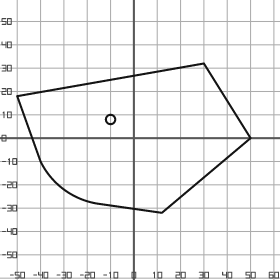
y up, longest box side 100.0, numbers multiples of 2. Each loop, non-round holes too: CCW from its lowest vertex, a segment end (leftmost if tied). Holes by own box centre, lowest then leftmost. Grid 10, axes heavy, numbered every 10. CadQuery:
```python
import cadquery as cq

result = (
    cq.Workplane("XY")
    .moveTo(12.0, -32.0)
    .lineTo(50.0, 0.0)
    .lineTo(30.0, 32.0)
    .lineTo(-50.0, 18.0)
    .lineTo(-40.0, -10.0)
    .threePointArc((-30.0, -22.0), (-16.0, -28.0))
    .close()
    .moveTo(-10.0, 8.0)
    .circle(2.0)
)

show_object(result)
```